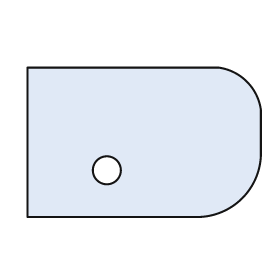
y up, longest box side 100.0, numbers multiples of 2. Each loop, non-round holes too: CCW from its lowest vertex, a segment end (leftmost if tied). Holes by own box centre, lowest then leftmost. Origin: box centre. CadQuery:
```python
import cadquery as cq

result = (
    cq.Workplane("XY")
    .moveTo(-50.0, -32.0)
    .lineTo(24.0, -32.0)
    .threePointArc((42.0, -24.0), (50.0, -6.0))
    .lineTo(50.0, 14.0)
    .threePointArc((44.0, 26.0), (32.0, 32.0))
    .lineTo(-50.0, 32.0)
    .close()
    .moveTo(-16.0, -12.0)
    .circle(6.0)
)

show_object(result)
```